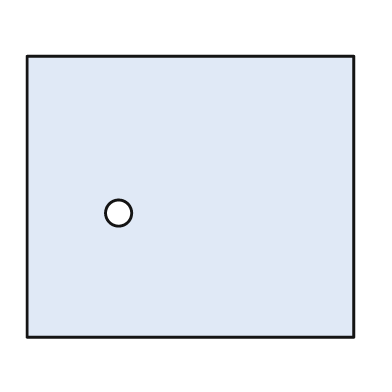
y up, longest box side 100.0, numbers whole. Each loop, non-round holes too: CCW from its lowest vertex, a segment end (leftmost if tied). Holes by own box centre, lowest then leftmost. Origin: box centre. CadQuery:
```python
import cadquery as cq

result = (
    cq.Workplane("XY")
    .moveTo(-50.0, -43.0)
    .lineTo(50.0, -43.0)
    .lineTo(50.0, 43.0)
    .lineTo(-50.0, 43.0)
    .close()
    .moveTo(-22.0, -5.0)
    .circle(4.0)
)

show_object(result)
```